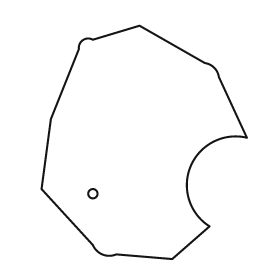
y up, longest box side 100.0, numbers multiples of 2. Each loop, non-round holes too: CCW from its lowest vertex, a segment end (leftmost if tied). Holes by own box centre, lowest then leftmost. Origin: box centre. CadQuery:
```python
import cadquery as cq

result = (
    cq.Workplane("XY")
    .moveTo(12.0, -50.0)
    .lineTo(28.0, -36.0)
    .threePointArc((20.0, -10.0), (44.0, 2.0))
    .lineTo(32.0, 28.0)
    .threePointArc((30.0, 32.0), (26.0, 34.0))
    .lineTo(-2.0, 50.0)
    .lineTo(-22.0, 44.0)
    .threePointArc((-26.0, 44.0), (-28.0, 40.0))
    .lineTo(-40.0, 10.0)
    .lineTo(-44.0, -20.0)
    .lineTo(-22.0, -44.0)
    .threePointArc((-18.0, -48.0), (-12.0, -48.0))
    .close()
    .moveTo(-22.0, -22.0)
    .circle(2.0)
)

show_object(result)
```